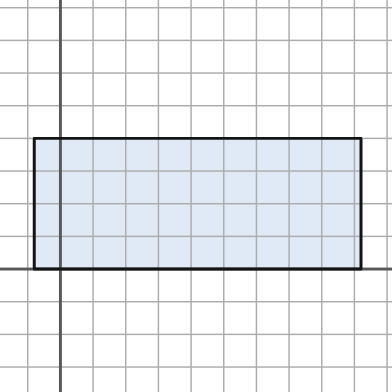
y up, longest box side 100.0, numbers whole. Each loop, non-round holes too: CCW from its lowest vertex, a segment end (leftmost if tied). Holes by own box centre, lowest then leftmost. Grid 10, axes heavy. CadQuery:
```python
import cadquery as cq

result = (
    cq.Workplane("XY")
    .moveTo(-8.0, 0.0)
    .lineTo(92.0, 0.0)
    .lineTo(92.0, 40.0)
    .lineTo(-8.0, 40.0)
    .close()
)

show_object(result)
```